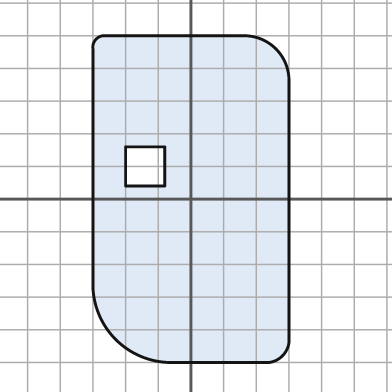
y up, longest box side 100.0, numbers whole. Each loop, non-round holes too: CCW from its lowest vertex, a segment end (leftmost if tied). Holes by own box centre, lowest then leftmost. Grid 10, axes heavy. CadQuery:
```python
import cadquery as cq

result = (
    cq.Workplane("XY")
    .moveTo(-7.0, -50.0)
    .lineTo(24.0, -50.0)
    .threePointArc((28.0, -48.0), (30.0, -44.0))
    .lineTo(30.0, 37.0)
    .threePointArc((26.0, 46.0), (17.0, 50.0))
    .lineTo(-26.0, 50.0)
    .threePointArc((-29.0, 49.0), (-30.0, 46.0))
    .lineTo(-30.0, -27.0)
    .threePointArc((-23.0, -43.0), (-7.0, -50.0))
    .close()
    .moveTo(-20.0, 4.0)
    .lineTo(-8.0, 4.0)
    .lineTo(-8.0, 16.0)
    .lineTo(-20.0, 16.0)
    .close()
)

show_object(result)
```